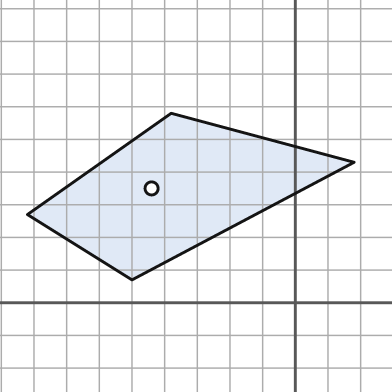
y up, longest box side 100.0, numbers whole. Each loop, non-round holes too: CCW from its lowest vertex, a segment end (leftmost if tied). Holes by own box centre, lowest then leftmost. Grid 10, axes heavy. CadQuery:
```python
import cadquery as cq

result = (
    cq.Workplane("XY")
    .moveTo(-50.0, 7.0)
    .lineTo(18.0, 43.0)
    .lineTo(-38.0, 58.0)
    .lineTo(-82.0, 27.0)
    .close()
    .moveTo(-44.0, 35.0)
    .circle(2.0)
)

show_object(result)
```